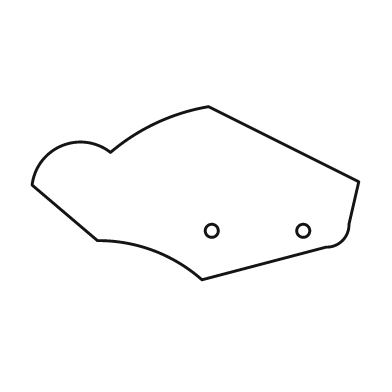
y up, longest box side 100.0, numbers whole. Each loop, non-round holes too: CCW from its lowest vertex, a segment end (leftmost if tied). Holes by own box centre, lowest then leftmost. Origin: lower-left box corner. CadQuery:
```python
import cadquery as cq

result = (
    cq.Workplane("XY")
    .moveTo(52.0, 0.0)
    .lineTo(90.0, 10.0)
    .threePointArc((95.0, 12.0), (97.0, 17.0))
    .lineTo(100.0, 30.0)
    .lineTo(54.0, 53.0)
    .threePointArc((38.0, 48.0), (24.0, 39.0))
    .threePointArc((9.0, 41.0), (0.0, 29.0))
    .lineTo(20.0, 12.0)
    .threePointArc((37.0, 9.0), (52.0, 0.0))
    .close()
    .moveTo(55.0, 15.0)
    .circle(2.0)
    .moveTo(83.0, 15.0)
    .circle(2.0)
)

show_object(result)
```